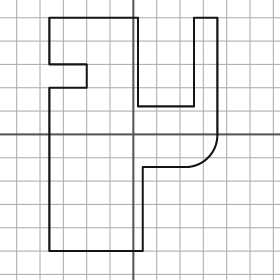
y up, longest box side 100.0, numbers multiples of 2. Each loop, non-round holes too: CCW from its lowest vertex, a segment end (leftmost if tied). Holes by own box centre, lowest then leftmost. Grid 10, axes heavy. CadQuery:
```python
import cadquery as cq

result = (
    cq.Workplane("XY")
    .moveTo(-36.0, -50.0)
    .lineTo(4.0, -50.0)
    .lineTo(4.0, -14.0)
    .lineTo(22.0, -14.0)
    .threePointArc((32.0, -10.0), (36.0, 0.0))
    .lineTo(36.0, 50.0)
    .lineTo(26.0, 50.0)
    .lineTo(26.0, 12.0)
    .lineTo(2.0, 12.0)
    .lineTo(2.0, 50.0)
    .lineTo(-36.0, 50.0)
    .lineTo(-36.0, 30.0)
    .lineTo(-20.0, 30.0)
    .lineTo(-20.0, 20.0)
    .lineTo(-36.0, 20.0)
    .close()
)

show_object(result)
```